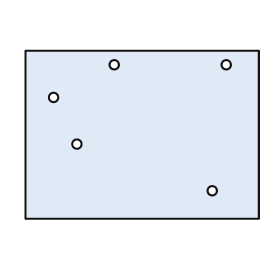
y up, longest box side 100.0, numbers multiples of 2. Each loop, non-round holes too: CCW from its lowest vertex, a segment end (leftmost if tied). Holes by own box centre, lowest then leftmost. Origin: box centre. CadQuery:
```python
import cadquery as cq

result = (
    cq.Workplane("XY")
    .moveTo(-50.0, -36.0)
    .lineTo(50.0, -36.0)
    .lineTo(50.0, 36.0)
    .lineTo(-50.0, 36.0)
    .close()
    .moveTo(30.0, -24.0)
    .circle(2.0)
    .moveTo(-28.0, -4.0)
    .circle(2.0)
    .moveTo(-38.0, 16.0)
    .circle(2.0)
    .moveTo(-12.0, 30.0)
    .circle(2.0)
    .moveTo(36.0, 30.0)
    .circle(2.0)
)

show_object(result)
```